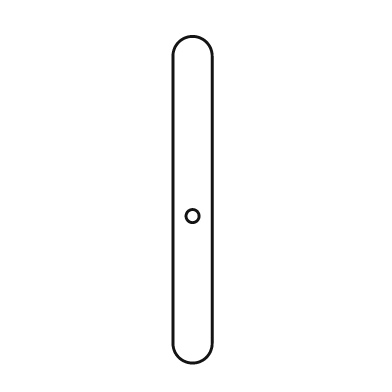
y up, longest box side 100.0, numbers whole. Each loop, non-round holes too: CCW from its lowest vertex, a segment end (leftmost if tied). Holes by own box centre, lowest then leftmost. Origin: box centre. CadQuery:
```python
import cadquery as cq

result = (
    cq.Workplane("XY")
    .moveTo(-6.0, -44.0)
    .threePointArc((0.0, -50.0), (6.0, -44.0))
    .lineTo(6.0, 44.0)
    .threePointArc((0.0, 50.0), (-6.0, 44.0))
    .close()
    .moveTo(0.0, -5.0)
    .circle(2.0)
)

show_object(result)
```